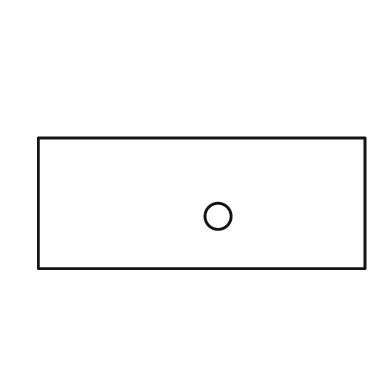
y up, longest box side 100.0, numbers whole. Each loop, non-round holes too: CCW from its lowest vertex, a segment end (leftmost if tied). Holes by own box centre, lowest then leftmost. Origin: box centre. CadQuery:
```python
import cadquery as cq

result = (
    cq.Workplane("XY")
    .moveTo(-50.0, -20.0)
    .lineTo(50.0, -20.0)
    .lineTo(50.0, 20.0)
    .lineTo(-50.0, 20.0)
    .close()
    .moveTo(5.0, -4.0)
    .circle(4.0)
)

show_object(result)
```